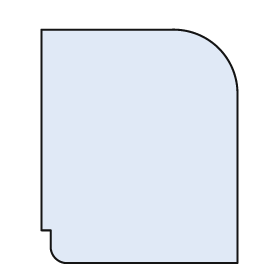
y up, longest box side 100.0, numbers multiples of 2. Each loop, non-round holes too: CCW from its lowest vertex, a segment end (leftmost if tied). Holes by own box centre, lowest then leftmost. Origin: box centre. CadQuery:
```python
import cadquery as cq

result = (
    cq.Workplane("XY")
    .moveTo(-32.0, -50.0)
    .lineTo(42.0, -50.0)
    .lineTo(42.0, 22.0)
    .threePointArc((34.0, 42.0), (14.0, 50.0))
    .lineTo(-42.0, 50.0)
    .lineTo(-42.0, -36.0)
    .lineTo(-38.0, -36.0)
    .lineTo(-38.0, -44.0)
    .threePointArc((-36.0, -48.0), (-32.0, -50.0))
    .close()
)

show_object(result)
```